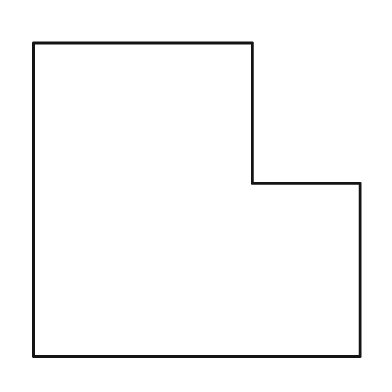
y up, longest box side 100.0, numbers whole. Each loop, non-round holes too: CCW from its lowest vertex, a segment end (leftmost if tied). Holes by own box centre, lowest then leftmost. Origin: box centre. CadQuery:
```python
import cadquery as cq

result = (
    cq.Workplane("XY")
    .moveTo(-50.0, -48.0)
    .lineTo(50.0, -48.0)
    .lineTo(50.0, 5.0)
    .lineTo(17.0, 5.0)
    .lineTo(17.0, 48.0)
    .lineTo(-50.0, 48.0)
    .close()
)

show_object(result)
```